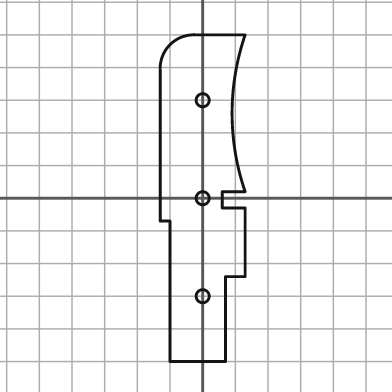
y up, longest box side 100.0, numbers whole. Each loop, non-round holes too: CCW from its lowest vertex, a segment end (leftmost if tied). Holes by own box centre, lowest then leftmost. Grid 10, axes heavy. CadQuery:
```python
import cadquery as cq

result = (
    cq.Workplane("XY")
    .moveTo(-10.0, -50.0)
    .lineTo(7.0, -50.0)
    .lineTo(7.0, -24.0)
    .lineTo(13.0, -24.0)
    .lineTo(13.0, -3.0)
    .lineTo(6.0, -3.0)
    .lineTo(6.0, 2.0)
    .lineTo(13.0, 2.0)
    .threePointArc((9.0, 26.0), (13.0, 50.0))
    .lineTo(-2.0, 50.0)
    .threePointArc((-10.0, 47.0), (-13.0, 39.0))
    .lineTo(-13.0, -7.0)
    .lineTo(-10.0, -7.0)
    .close()
    .moveTo(0.0, -30.0)
    .circle(2.0)
    .moveTo(0.0, 0.0)
    .circle(2.0)
    .moveTo(0.0, 30.0)
    .circle(2.0)
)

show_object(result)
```